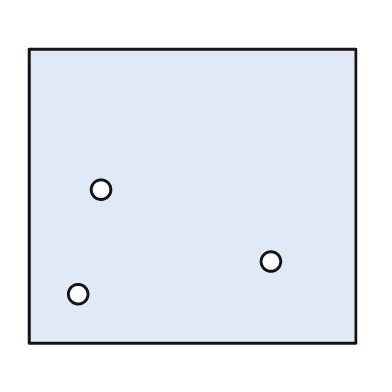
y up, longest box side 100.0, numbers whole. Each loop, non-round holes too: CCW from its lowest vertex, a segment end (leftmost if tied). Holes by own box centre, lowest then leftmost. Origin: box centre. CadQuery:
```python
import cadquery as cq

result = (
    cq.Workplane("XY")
    .moveTo(-50.0, -45.0)
    .lineTo(50.0, -45.0)
    .lineTo(50.0, 45.0)
    .lineTo(-50.0, 45.0)
    .close()
    .moveTo(-35.0, -30.0)
    .circle(3.0)
    .moveTo(24.0, -20.0)
    .circle(3.0)
    .moveTo(-28.0, 2.0)
    .circle(3.0)
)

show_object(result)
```